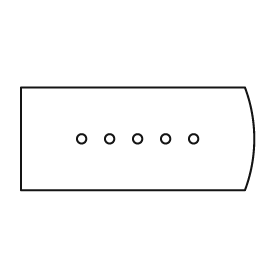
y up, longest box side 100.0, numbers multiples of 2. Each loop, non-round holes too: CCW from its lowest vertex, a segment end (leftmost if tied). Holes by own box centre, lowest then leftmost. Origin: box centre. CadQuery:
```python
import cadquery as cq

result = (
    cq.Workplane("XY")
    .moveTo(-50.0, -22.0)
    .lineTo(46.0, -22.0)
    .threePointArc((50.0, 0.0), (46.0, 22.0))
    .lineTo(-50.0, 22.0)
    .close()
    .moveTo(-24.0, 0.0)
    .circle(2.0)
    .moveTo(-12.0, 0.0)
    .circle(2.0)
    .moveTo(0.0, 0.0)
    .circle(2.0)
    .moveTo(12.0, 0.0)
    .circle(2.0)
    .moveTo(24.0, 0.0)
    .circle(2.0)
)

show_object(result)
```